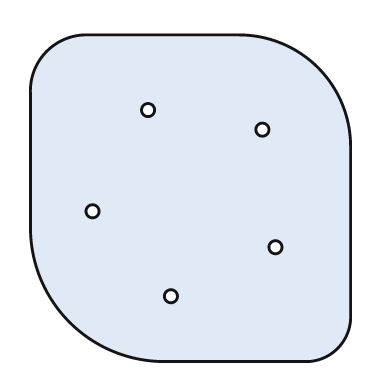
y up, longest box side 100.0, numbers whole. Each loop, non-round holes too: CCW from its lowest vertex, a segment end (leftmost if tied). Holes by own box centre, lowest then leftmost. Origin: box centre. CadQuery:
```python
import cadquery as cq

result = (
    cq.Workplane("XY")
    .moveTo(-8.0, -50.0)
    .lineTo(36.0, -50.0)
    .threePointArc((45.0, -46.0), (49.0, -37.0))
    .lineTo(49.0, 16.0)
    .threePointArc((39.0, 40.0), (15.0, 50.0))
    .lineTo(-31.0, 50.0)
    .threePointArc((-44.0, 45.0), (-49.0, 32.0))
    .lineTo(-49.0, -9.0)
    .threePointArc((-37.0, -38.0), (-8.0, -50.0))
    .close()
    .moveTo(-6.0, -30.0)
    .circle(2.0)
    .moveTo(26.0, -15.0)
    .circle(2.0)
    .moveTo(-30.0, -4.0)
    .circle(2.0)
    .moveTo(22.0, 21.0)
    .circle(2.0)
    .moveTo(-13.0, 27.0)
    .circle(2.0)
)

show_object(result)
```